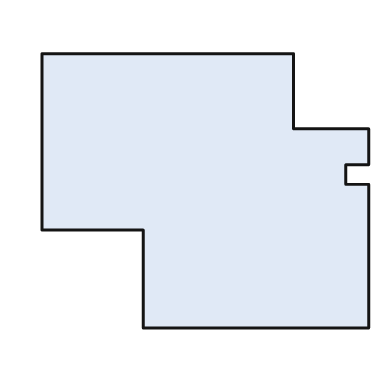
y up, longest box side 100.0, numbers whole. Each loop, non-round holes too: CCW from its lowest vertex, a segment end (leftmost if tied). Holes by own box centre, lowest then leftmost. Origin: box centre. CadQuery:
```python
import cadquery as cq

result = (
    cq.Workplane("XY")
    .moveTo(-19.0, -42.0)
    .lineTo(50.0, -42.0)
    .lineTo(50.0, 2.0)
    .lineTo(43.0, 2.0)
    .lineTo(43.0, 8.0)
    .lineTo(50.0, 8.0)
    .lineTo(50.0, 19.0)
    .lineTo(27.0, 19.0)
    .lineTo(27.0, 42.0)
    .lineTo(-50.0, 42.0)
    .lineTo(-50.0, -12.0)
    .lineTo(-19.0, -12.0)
    .close()
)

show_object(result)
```